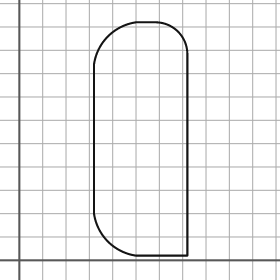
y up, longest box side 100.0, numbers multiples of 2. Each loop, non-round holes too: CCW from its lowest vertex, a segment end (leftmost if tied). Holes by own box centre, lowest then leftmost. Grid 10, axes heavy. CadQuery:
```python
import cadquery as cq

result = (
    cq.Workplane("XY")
    .moveTo(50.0, 2.0)
    .lineTo(72.0, 2.0)
    .lineTo(72.0, 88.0)
    .threePointArc((68.0, 98.0), (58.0, 102.0))
    .lineTo(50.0, 102.0)
    .threePointArc((38.0, 96.0), (32.0, 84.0))
    .lineTo(32.0, 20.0)
    .threePointArc((38.0, 8.0), (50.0, 2.0))
    .close()
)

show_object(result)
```